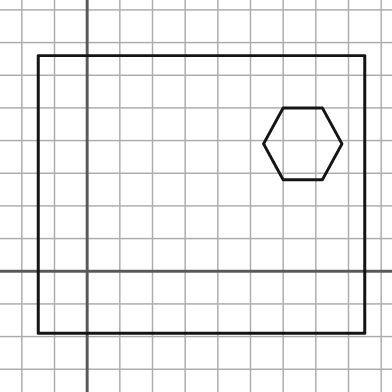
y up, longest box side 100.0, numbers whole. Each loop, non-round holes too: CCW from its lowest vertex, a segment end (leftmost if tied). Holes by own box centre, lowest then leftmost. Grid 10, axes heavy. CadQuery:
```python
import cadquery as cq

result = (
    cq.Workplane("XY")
    .moveTo(-15.0, -19.0)
    .lineTo(85.0, -19.0)
    .lineTo(85.0, 66.0)
    .lineTo(-15.0, 66.0)
    .close()
    .moveTo(60.0, 28.0)
    .lineTo(72.0, 28.0)
    .lineTo(78.0, 39.0)
    .lineTo(72.0, 50.0)
    .lineTo(60.0, 50.0)
    .lineTo(54.0, 39.0)
    .close()
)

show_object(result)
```